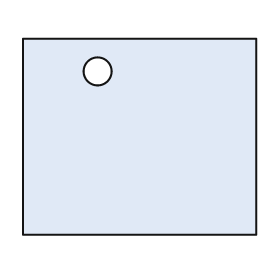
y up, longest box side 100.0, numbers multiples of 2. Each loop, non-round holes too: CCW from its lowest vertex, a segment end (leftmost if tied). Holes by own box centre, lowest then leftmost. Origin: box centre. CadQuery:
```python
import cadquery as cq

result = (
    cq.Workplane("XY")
    .moveTo(-50.0, -42.0)
    .lineTo(50.0, -42.0)
    .lineTo(50.0, 42.0)
    .lineTo(-50.0, 42.0)
    .close()
    .moveTo(-18.0, 28.0)
    .circle(6.0)
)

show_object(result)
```